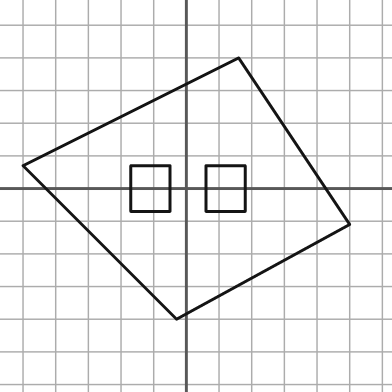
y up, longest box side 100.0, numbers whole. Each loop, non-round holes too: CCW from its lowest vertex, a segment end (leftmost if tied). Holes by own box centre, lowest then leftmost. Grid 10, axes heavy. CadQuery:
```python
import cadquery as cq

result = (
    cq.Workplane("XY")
    .moveTo(-3.0, -40.0)
    .lineTo(50.0, -11.0)
    .lineTo(16.0, 40.0)
    .lineTo(-50.0, 7.0)
    .close()
    .moveTo(-17.0, -7.0)
    .lineTo(-5.0, -7.0)
    .lineTo(-5.0, 7.0)
    .lineTo(-17.0, 7.0)
    .close()
    .moveTo(6.0, -7.0)
    .lineTo(18.0, -7.0)
    .lineTo(18.0, 7.0)
    .lineTo(6.0, 7.0)
    .close()
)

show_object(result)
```